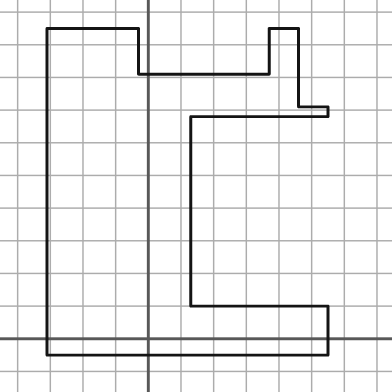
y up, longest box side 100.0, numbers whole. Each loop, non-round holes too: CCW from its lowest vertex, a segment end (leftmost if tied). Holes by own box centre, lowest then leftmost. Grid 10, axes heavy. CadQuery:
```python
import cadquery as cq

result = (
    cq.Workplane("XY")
    .moveTo(-31.0, -5.0)
    .lineTo(55.0, -5.0)
    .lineTo(55.0, 10.0)
    .lineTo(13.0, 10.0)
    .lineTo(13.0, 68.0)
    .lineTo(55.0, 68.0)
    .lineTo(55.0, 71.0)
    .lineTo(46.0, 71.0)
    .lineTo(46.0, 95.0)
    .lineTo(37.0, 95.0)
    .lineTo(37.0, 81.0)
    .lineTo(-3.0, 81.0)
    .lineTo(-3.0, 95.0)
    .lineTo(-31.0, 95.0)
    .close()
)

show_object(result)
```